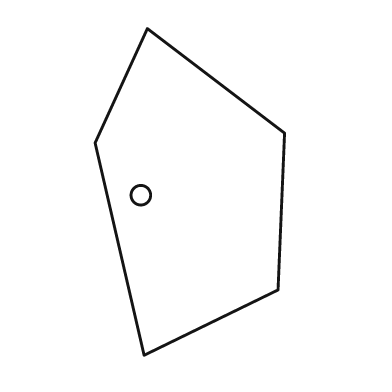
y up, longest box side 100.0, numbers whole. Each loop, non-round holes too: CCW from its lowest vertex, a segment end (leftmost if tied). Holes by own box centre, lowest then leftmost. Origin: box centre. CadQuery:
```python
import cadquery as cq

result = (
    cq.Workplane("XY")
    .moveTo(-14.0, -50.0)
    .lineTo(27.0, -30.0)
    .lineTo(29.0, 18.0)
    .lineTo(-13.0, 50.0)
    .lineTo(-29.0, 15.0)
    .close()
    .moveTo(-15.0, -1.0)
    .circle(3.0)
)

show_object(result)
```